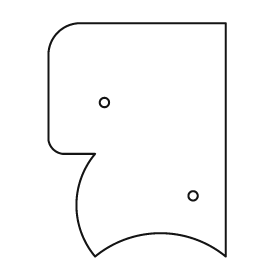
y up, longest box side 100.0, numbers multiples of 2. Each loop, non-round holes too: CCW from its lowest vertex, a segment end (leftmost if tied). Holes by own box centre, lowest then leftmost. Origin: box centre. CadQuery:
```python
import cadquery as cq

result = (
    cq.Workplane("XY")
    .moveTo(-18.0, -50.0)
    .threePointArc((10.0, -40.0), (38.0, -50.0))
    .lineTo(38.0, 50.0)
    .lineTo(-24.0, 50.0)
    .threePointArc((-34.0, 46.0), (-38.0, 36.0))
    .lineTo(-38.0, 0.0)
    .threePointArc((-36.0, -4.0), (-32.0, -6.0))
    .lineTo(-18.0, -6.0)
    .threePointArc((-26.0, -28.0), (-18.0, -50.0))
    .close()
    .moveTo(24.0, -24.0)
    .circle(2.0)
    .moveTo(-14.0, 16.0)
    .circle(2.0)
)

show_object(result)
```